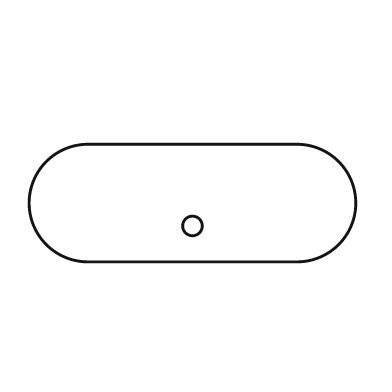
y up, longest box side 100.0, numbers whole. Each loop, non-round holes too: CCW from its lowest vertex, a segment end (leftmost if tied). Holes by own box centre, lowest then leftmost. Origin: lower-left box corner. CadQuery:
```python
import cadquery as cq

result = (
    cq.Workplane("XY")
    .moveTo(18.0, 0.0)
    .lineTo(82.0, 0.0)
    .threePointArc((100.0, 18.0), (82.0, 36.0))
    .lineTo(18.0, 36.0)
    .threePointArc((0.0, 18.0), (18.0, 0.0))
    .close()
    .moveTo(50.0, 11.0)
    .circle(3.0)
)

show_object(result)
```